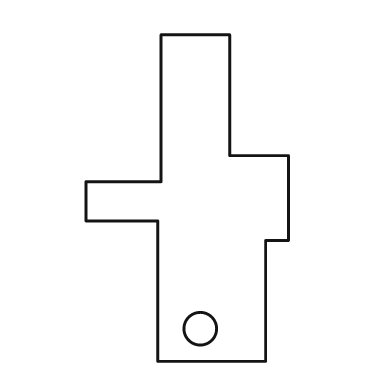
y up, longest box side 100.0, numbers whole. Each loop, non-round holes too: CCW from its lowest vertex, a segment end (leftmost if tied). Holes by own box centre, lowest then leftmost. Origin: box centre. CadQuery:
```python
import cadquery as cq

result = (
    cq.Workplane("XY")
    .moveTo(-9.0, -50.0)
    .lineTo(24.0, -50.0)
    .lineTo(24.0, -13.0)
    .lineTo(31.0, -13.0)
    .lineTo(31.0, 13.0)
    .lineTo(13.0, 13.0)
    .lineTo(13.0, 50.0)
    .lineTo(-8.0, 50.0)
    .lineTo(-8.0, 5.0)
    .lineTo(-31.0, 5.0)
    .lineTo(-31.0, -7.0)
    .lineTo(-9.0, -7.0)
    .close()
    .moveTo(4.0, -40.0)
    .circle(5.0)
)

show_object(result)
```